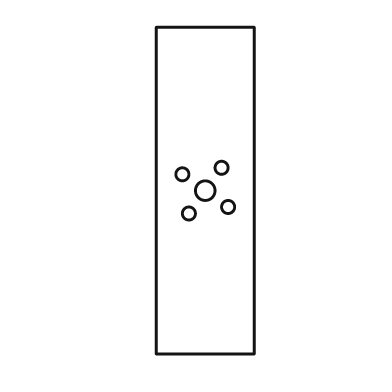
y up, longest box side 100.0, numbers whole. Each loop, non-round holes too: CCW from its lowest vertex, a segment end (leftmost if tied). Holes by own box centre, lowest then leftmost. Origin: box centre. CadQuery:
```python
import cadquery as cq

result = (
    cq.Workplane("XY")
    .moveTo(-15.0, -50.0)
    .lineTo(15.0, -50.0)
    .lineTo(15.0, 50.0)
    .lineTo(-15.0, 50.0)
    .close()
    .moveTo(-5.0, -7.0)
    .circle(2.0)
    .moveTo(7.0, -5.0)
    .circle(2.0)
    .moveTo(0.0, 0.0)
    .circle(3.0)
    .moveTo(-7.0, 5.0)
    .circle(2.0)
    .moveTo(5.0, 7.0)
    .circle(2.0)
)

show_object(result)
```